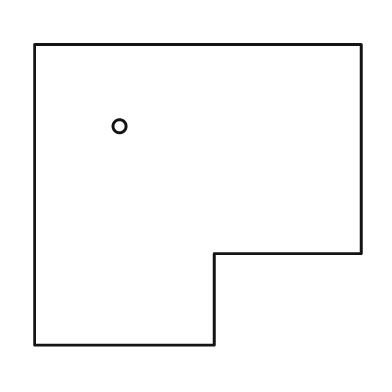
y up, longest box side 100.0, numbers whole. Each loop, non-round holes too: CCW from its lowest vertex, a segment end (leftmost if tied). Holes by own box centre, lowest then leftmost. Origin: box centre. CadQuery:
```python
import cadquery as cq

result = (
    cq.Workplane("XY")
    .moveTo(-50.0, -46.0)
    .lineTo(5.0, -46.0)
    .lineTo(5.0, -18.0)
    .lineTo(50.0, -18.0)
    .lineTo(50.0, 46.0)
    .lineTo(-50.0, 46.0)
    .close()
    .moveTo(-24.0, 21.0)
    .circle(2.0)
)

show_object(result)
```